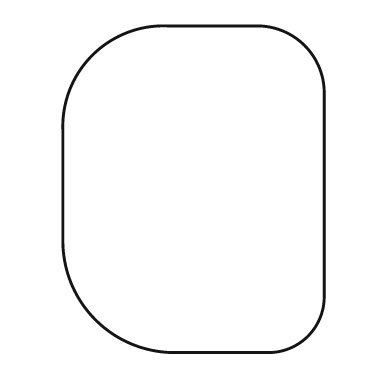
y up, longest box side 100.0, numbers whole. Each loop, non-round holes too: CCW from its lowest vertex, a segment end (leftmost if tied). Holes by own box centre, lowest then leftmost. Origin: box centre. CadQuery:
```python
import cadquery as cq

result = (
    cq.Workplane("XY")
    .moveTo(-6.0, -50.0)
    .lineTo(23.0, -50.0)
    .threePointArc((35.0, -45.0), (40.0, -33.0))
    .lineTo(40.0, 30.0)
    .threePointArc((34.0, 44.0), (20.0, 50.0))
    .lineTo(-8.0, 50.0)
    .threePointArc((-31.0, 41.0), (-40.0, 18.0))
    .lineTo(-40.0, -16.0)
    .threePointArc((-30.0, -40.0), (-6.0, -50.0))
    .close()
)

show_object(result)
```